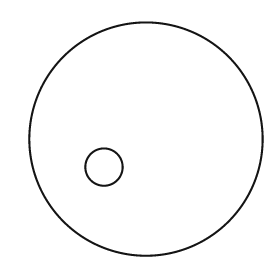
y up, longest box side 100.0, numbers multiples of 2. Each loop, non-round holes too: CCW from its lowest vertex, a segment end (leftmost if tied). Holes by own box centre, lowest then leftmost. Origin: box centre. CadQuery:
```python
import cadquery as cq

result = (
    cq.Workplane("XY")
    .moveTo(0.0, 0.0)
    .circle(50.0)
    .moveTo(-18.0, -12.0)
    .circle(8.0)
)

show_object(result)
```